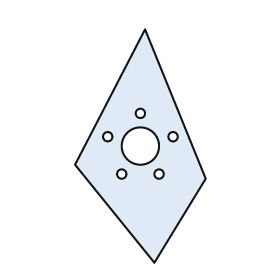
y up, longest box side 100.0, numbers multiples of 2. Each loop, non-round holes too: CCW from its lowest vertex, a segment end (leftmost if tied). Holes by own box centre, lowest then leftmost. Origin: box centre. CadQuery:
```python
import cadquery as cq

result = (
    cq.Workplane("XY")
    .moveTo(6.0, -50.0)
    .lineTo(28.0, -14.0)
    .lineTo(2.0, 50.0)
    .lineTo(-28.0, -8.0)
    .close()
    .moveTo(-8.0, -12.0)
    .circle(2.0)
    .moveTo(8.0, -12.0)
    .circle(2.0)
    .moveTo(0.0, 0.0)
    .circle(8.0)
    .moveTo(-14.0, 4.0)
    .circle(2.0)
    .moveTo(14.0, 4.0)
    .circle(2.0)
    .moveTo(0.0, 14.0)
    .circle(2.0)
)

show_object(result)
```